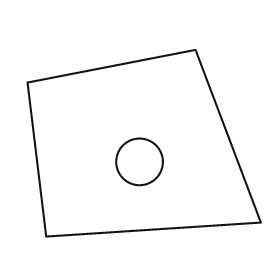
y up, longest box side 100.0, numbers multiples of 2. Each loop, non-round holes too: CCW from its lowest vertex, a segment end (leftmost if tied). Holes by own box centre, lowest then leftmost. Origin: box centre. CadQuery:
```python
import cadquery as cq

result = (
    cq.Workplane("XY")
    .moveTo(-42.0, -40.0)
    .lineTo(50.0, -34.0)
    .lineTo(22.0, 40.0)
    .lineTo(-50.0, 26.0)
    .close()
    .moveTo(-2.0, -8.0)
    .circle(10.0)
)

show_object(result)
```